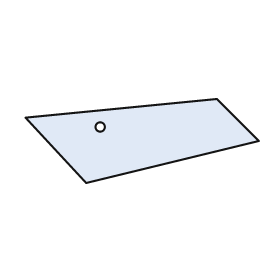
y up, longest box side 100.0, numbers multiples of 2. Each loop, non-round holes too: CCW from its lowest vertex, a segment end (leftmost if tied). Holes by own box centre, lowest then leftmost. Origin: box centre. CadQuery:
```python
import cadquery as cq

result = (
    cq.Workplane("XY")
    .moveTo(-24.0, -18.0)
    .lineTo(50.0, 0.0)
    .lineTo(32.0, 18.0)
    .lineTo(-50.0, 10.0)
    .close()
    .moveTo(-18.0, 6.0)
    .circle(2.0)
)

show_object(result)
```